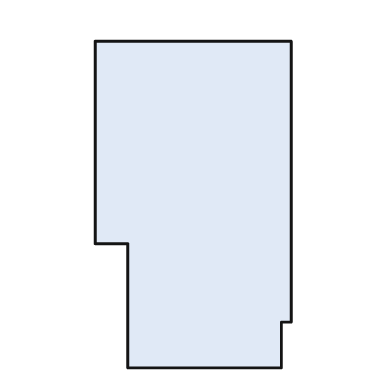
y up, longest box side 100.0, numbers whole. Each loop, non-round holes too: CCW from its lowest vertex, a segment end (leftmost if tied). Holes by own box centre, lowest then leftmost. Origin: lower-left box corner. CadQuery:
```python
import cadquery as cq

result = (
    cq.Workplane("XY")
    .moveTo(10.0, 0.0)
    .lineTo(57.0, 0.0)
    .lineTo(57.0, 14.0)
    .lineTo(60.0, 14.0)
    .lineTo(60.0, 100.0)
    .lineTo(0.0, 100.0)
    .lineTo(0.0, 38.0)
    .lineTo(10.0, 38.0)
    .close()
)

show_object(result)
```